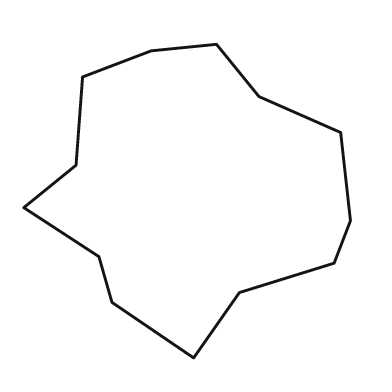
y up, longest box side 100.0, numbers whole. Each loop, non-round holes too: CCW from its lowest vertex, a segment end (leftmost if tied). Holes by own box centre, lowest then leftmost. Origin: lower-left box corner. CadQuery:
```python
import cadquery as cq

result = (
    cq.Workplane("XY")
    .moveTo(52.0, 0.0)
    .lineTo(66.0, 20.0)
    .lineTo(95.0, 29.0)
    .lineTo(100.0, 42.0)
    .lineTo(97.0, 69.0)
    .lineTo(72.0, 80.0)
    .lineTo(59.0, 96.0)
    .lineTo(39.0, 94.0)
    .lineTo(18.0, 86.0)
    .lineTo(16.0, 59.0)
    .lineTo(0.0, 46.0)
    .lineTo(23.0, 31.0)
    .lineTo(27.0, 17.0)
    .close()
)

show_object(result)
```